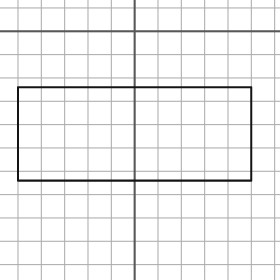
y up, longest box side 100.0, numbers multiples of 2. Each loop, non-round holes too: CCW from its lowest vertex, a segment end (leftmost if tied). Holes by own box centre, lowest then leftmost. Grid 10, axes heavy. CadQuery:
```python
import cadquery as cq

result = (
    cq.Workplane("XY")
    .moveTo(-50.0, -64.0)
    .lineTo(50.0, -64.0)
    .lineTo(50.0, -24.0)
    .lineTo(-50.0, -24.0)
    .close()
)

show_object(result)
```